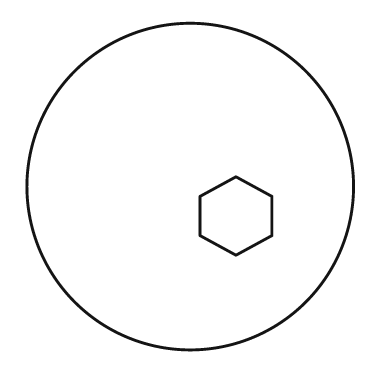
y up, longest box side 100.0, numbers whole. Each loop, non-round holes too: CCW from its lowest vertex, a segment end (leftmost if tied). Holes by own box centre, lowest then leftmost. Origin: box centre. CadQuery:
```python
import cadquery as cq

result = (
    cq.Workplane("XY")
    .moveTo(0.0, 0.0)
    .circle(50.0)
    .moveTo(14.0, -21.0)
    .lineTo(25.0, -15.0)
    .lineTo(25.0, -3.0)
    .lineTo(14.0, 3.0)
    .lineTo(3.0, -3.0)
    .lineTo(3.0, -15.0)
    .close()
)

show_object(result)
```